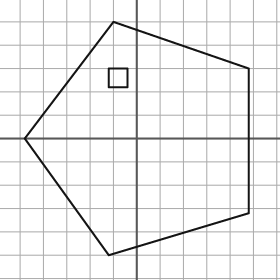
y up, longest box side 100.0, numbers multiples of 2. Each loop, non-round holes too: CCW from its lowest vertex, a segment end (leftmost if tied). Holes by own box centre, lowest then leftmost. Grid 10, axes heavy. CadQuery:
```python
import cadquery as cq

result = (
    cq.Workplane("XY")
    .moveTo(-12.0, -50.0)
    .lineTo(48.0, -32.0)
    .lineTo(48.0, 30.0)
    .lineTo(-10.0, 50.0)
    .lineTo(-48.0, 0.0)
    .close()
    .moveTo(-12.0, 22.0)
    .lineTo(-4.0, 22.0)
    .lineTo(-4.0, 30.0)
    .lineTo(-12.0, 30.0)
    .close()
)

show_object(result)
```